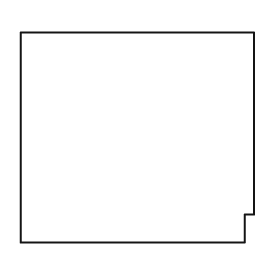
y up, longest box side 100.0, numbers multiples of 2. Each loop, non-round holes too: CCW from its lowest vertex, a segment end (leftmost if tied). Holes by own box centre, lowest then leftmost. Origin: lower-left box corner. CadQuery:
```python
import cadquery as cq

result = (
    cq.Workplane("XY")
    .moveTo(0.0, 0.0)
    .lineTo(96.0, 0.0)
    .lineTo(96.0, 12.0)
    .lineTo(100.0, 12.0)
    .lineTo(100.0, 90.0)
    .lineTo(0.0, 90.0)
    .close()
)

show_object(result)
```